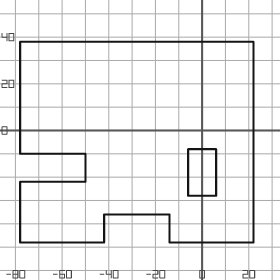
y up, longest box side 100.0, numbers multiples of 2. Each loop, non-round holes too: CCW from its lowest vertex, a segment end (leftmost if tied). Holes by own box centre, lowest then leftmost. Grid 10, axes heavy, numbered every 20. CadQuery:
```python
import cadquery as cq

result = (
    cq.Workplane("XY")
    .moveTo(-78.0, -48.0)
    .lineTo(-42.0, -48.0)
    .lineTo(-42.0, -36.0)
    .lineTo(-14.0, -36.0)
    .lineTo(-14.0, -48.0)
    .lineTo(22.0, -48.0)
    .lineTo(22.0, 38.0)
    .lineTo(-78.0, 38.0)
    .lineTo(-78.0, -10.0)
    .lineTo(-50.0, -10.0)
    .lineTo(-50.0, -22.0)
    .lineTo(-78.0, -22.0)
    .close()
    .moveTo(-6.0, -28.0)
    .lineTo(6.0, -28.0)
    .lineTo(6.0, -8.0)
    .lineTo(-6.0, -8.0)
    .close()
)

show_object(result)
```